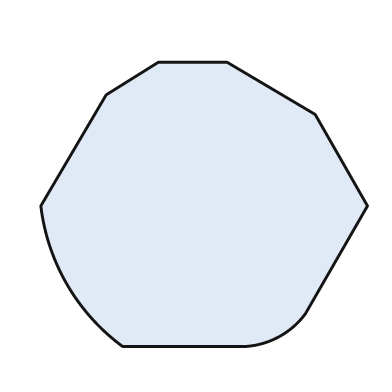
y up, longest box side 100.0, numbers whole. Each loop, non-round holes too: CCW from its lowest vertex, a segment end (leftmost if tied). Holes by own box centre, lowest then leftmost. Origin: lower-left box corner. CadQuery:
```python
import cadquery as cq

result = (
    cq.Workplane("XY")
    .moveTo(25.0, 0.0)
    .lineTo(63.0, 0.0)
    .threePointArc((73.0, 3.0), (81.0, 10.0))
    .lineTo(100.0, 43.0)
    .lineTo(84.0, 71.0)
    .lineTo(57.0, 87.0)
    .lineTo(36.0, 87.0)
    .lineTo(20.0, 77.0)
    .lineTo(0.0, 43.0)
    .threePointArc((8.0, 19.0), (25.0, 0.0))
    .close()
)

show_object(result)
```